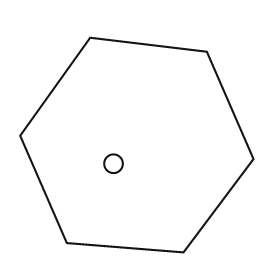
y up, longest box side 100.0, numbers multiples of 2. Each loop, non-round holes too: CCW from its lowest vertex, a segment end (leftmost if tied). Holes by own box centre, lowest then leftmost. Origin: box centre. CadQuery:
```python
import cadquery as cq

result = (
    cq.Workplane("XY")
    .moveTo(20.0, -46.0)
    .lineTo(50.0, -6.0)
    .lineTo(30.0, 40.0)
    .lineTo(-20.0, 46.0)
    .lineTo(-50.0, 4.0)
    .lineTo(-30.0, -42.0)
    .close()
    .moveTo(-10.0, -8.0)
    .circle(4.0)
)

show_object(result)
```